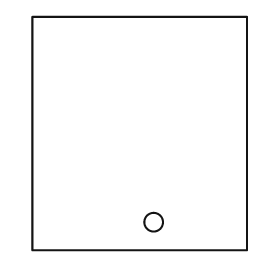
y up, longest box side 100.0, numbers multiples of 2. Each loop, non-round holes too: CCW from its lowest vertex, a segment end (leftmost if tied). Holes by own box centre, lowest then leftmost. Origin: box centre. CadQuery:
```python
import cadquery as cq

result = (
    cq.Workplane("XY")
    .moveTo(-46.0, -50.0)
    .lineTo(46.0, -50.0)
    .lineTo(46.0, 50.0)
    .lineTo(-46.0, 50.0)
    .close()
    .moveTo(6.0, -38.0)
    .circle(4.0)
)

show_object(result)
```